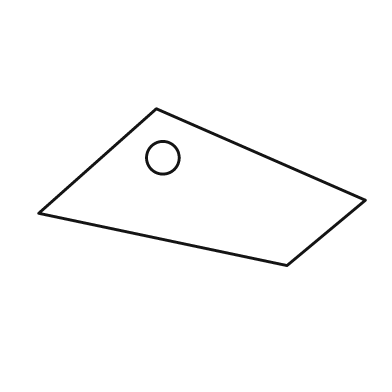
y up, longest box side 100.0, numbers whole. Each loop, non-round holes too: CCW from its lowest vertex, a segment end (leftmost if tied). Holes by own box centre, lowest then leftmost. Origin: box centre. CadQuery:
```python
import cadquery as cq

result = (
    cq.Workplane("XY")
    .moveTo(26.0, -24.0)
    .lineTo(50.0, -4.0)
    .lineTo(-14.0, 24.0)
    .lineTo(-50.0, -8.0)
    .close()
    .moveTo(-12.0, 9.0)
    .circle(5.0)
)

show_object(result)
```